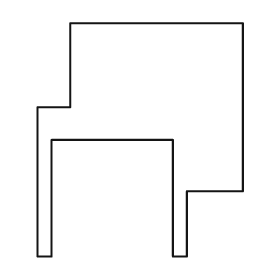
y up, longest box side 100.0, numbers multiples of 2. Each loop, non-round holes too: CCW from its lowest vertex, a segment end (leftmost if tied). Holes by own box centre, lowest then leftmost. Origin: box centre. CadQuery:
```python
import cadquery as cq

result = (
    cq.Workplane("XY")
    .moveTo(-44.0, -50.0)
    .lineTo(-38.0, -50.0)
    .lineTo(-38.0, 0.0)
    .lineTo(14.0, 0.0)
    .lineTo(14.0, -50.0)
    .lineTo(20.0, -50.0)
    .lineTo(20.0, -22.0)
    .lineTo(44.0, -22.0)
    .lineTo(44.0, 50.0)
    .lineTo(-30.0, 50.0)
    .lineTo(-30.0, 14.0)
    .lineTo(-44.0, 14.0)
    .close()
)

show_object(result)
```